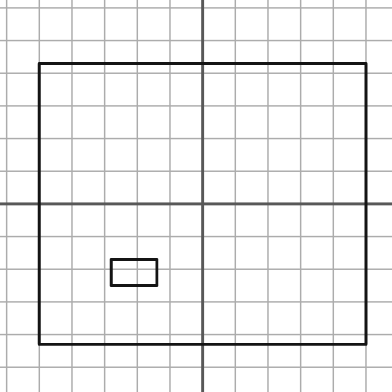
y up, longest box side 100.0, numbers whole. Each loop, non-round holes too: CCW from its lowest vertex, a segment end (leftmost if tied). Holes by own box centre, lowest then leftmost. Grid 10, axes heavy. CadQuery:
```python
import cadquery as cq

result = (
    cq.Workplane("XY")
    .moveTo(-50.0, -43.0)
    .lineTo(50.0, -43.0)
    .lineTo(50.0, 43.0)
    .lineTo(-50.0, 43.0)
    .close()
    .moveTo(-28.0, -25.0)
    .lineTo(-14.0, -25.0)
    .lineTo(-14.0, -17.0)
    .lineTo(-28.0, -17.0)
    .close()
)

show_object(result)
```